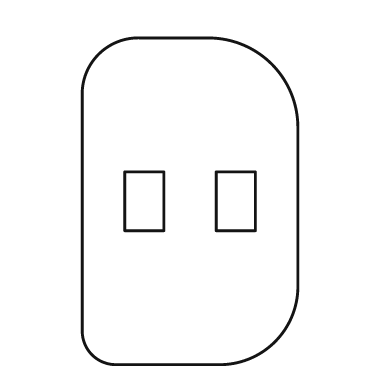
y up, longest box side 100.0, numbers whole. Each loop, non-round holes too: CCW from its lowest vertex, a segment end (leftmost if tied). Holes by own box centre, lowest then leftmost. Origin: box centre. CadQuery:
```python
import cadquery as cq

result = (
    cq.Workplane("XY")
    .moveTo(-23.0, -50.0)
    .lineTo(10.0, -50.0)
    .threePointArc((26.0, -43.0), (33.0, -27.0))
    .lineTo(33.0, 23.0)
    .threePointArc((25.0, 42.0), (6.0, 50.0))
    .lineTo(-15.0, 50.0)
    .threePointArc((-28.0, 45.0), (-33.0, 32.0))
    .lineTo(-33.0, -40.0)
    .threePointArc((-30.0, -47.0), (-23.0, -50.0))
    .close()
    .moveTo(-20.0, -9.0)
    .lineTo(-8.0, -9.0)
    .lineTo(-8.0, 9.0)
    .lineTo(-20.0, 9.0)
    .close()
    .moveTo(8.0, -9.0)
    .lineTo(20.0, -9.0)
    .lineTo(20.0, 9.0)
    .lineTo(8.0, 9.0)
    .close()
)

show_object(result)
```